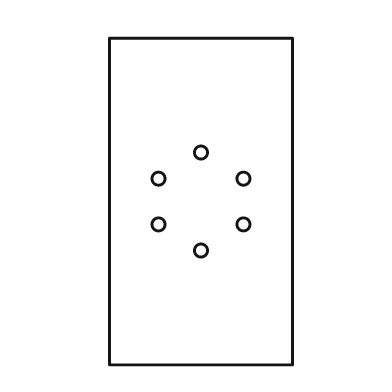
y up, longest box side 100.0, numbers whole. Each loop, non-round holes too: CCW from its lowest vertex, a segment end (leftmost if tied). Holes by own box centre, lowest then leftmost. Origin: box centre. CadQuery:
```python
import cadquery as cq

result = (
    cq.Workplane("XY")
    .moveTo(-28.0, -50.0)
    .lineTo(28.0, -50.0)
    .lineTo(28.0, 50.0)
    .lineTo(-28.0, 50.0)
    .close()
    .moveTo(0.0, -15.0)
    .circle(2.0)
    .moveTo(-13.0, -7.0)
    .circle(2.0)
    .moveTo(13.0, -7.0)
    .circle(2.0)
    .moveTo(-13.0, 7.0)
    .circle(2.0)
    .moveTo(13.0, 7.0)
    .circle(2.0)
    .moveTo(0.0, 15.0)
    .circle(2.0)
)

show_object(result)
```